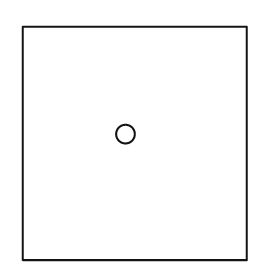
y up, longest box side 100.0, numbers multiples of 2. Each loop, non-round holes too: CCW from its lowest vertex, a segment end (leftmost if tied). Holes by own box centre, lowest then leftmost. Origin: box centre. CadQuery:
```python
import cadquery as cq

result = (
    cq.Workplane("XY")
    .moveTo(-48.0, -50.0)
    .lineTo(48.0, -50.0)
    .lineTo(48.0, 50.0)
    .lineTo(-48.0, 50.0)
    .close()
    .moveTo(-4.0, 4.0)
    .circle(4.0)
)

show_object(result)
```